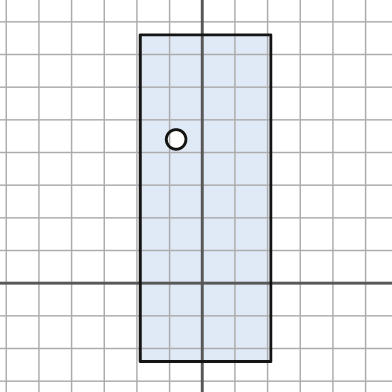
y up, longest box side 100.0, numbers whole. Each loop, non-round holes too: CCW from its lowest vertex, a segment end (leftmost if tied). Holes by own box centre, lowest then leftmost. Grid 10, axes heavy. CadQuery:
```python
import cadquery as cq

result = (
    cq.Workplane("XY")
    .moveTo(-19.0, -24.0)
    .lineTo(21.0, -24.0)
    .lineTo(21.0, 76.0)
    .lineTo(-19.0, 76.0)
    .close()
    .moveTo(-8.0, 44.0)
    .circle(3.0)
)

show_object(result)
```